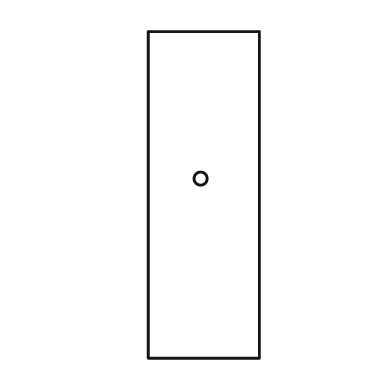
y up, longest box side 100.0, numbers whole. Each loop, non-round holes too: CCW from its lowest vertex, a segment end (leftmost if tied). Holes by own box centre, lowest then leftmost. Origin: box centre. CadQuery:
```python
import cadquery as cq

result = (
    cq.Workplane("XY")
    .moveTo(-17.0, -50.0)
    .lineTo(17.0, -50.0)
    .lineTo(17.0, 50.0)
    .lineTo(-17.0, 50.0)
    .close()
    .moveTo(-1.0, 5.0)
    .circle(2.0)
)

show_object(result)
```